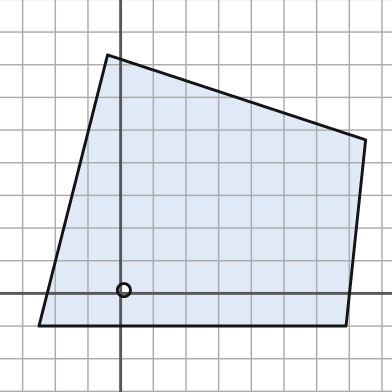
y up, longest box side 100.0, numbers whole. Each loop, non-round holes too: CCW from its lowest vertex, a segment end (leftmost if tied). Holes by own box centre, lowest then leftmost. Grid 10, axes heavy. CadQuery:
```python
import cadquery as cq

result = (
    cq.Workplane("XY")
    .moveTo(-25.0, -10.0)
    .lineTo(69.0, -10.0)
    .lineTo(75.0, 47.0)
    .lineTo(-4.0, 73.0)
    .close()
    .moveTo(1.0, 1.0)
    .circle(2.0)
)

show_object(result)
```